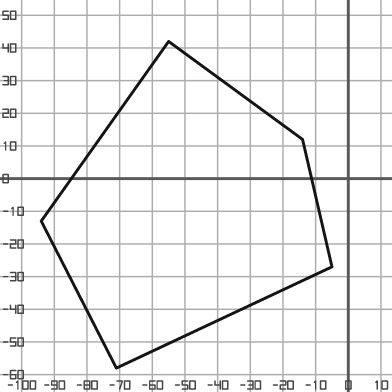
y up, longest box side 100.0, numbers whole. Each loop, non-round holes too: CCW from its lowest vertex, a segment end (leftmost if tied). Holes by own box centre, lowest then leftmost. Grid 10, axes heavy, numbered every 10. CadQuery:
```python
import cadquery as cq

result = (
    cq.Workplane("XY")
    .moveTo(-71.0, -58.0)
    .lineTo(-5.0, -27.0)
    .lineTo(-14.0, 12.0)
    .lineTo(-55.0, 42.0)
    .lineTo(-94.0, -13.0)
    .close()
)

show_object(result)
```